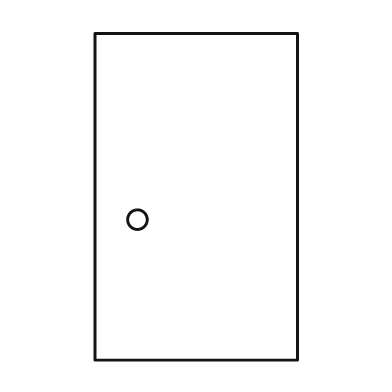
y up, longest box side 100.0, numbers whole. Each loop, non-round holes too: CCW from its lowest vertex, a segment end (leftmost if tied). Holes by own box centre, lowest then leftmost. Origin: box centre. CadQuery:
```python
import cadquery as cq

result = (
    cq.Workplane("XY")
    .moveTo(-31.0, -50.0)
    .lineTo(31.0, -50.0)
    .lineTo(31.0, 50.0)
    .lineTo(-31.0, 50.0)
    .close()
    .moveTo(-18.0, -7.0)
    .circle(3.0)
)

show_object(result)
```